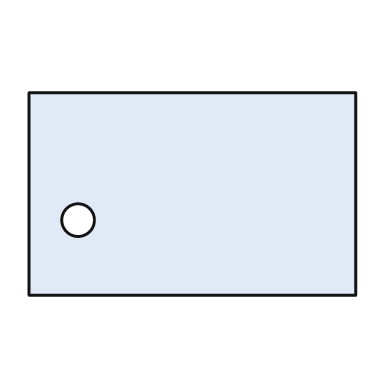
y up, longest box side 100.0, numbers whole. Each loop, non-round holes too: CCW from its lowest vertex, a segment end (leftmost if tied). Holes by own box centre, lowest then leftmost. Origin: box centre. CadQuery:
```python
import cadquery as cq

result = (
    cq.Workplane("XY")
    .moveTo(-50.0, -31.0)
    .lineTo(50.0, -31.0)
    .lineTo(50.0, 31.0)
    .lineTo(-50.0, 31.0)
    .close()
    .moveTo(-35.0, -8.0)
    .circle(5.0)
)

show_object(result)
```